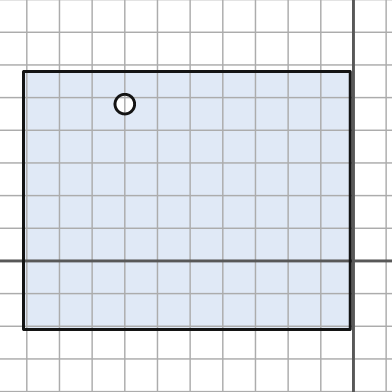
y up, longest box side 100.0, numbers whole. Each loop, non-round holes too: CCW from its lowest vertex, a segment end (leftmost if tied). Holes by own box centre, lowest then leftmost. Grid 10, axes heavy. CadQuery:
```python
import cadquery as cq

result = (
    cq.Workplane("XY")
    .moveTo(-101.0, -21.0)
    .lineTo(-1.0, -21.0)
    .lineTo(-1.0, 58.0)
    .lineTo(-101.0, 58.0)
    .close()
    .moveTo(-70.0, 48.0)
    .circle(3.0)
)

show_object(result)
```